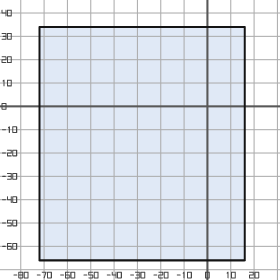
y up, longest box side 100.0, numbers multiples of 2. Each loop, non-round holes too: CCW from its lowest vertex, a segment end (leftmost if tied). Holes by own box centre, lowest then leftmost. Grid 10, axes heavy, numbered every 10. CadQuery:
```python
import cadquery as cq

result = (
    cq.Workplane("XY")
    .moveTo(-72.0, -66.0)
    .lineTo(16.0, -66.0)
    .lineTo(16.0, 34.0)
    .lineTo(-72.0, 34.0)
    .close()
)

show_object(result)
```